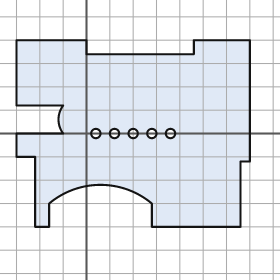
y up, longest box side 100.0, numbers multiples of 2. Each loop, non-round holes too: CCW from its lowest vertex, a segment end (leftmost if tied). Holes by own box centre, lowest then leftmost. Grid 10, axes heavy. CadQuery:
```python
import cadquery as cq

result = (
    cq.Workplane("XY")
    .moveTo(-22.0, -40.0)
    .lineTo(-16.0, -40.0)
    .lineTo(-16.0, -30.0)
    .threePointArc((6.0, -22.0), (28.0, -30.0))
    .lineTo(28.0, -40.0)
    .lineTo(66.0, -40.0)
    .lineTo(66.0, -12.0)
    .lineTo(70.0, -12.0)
    .lineTo(70.0, 40.0)
    .lineTo(46.0, 40.0)
    .lineTo(46.0, 34.0)
    .lineTo(0.0, 34.0)
    .lineTo(0.0, 40.0)
    .lineTo(-30.0, 40.0)
    .lineTo(-30.0, 12.0)
    .lineTo(-10.0, 12.0)
    .threePointArc((-12.0, 6.0), (-10.0, 0.0))
    .lineTo(-30.0, 0.0)
    .lineTo(-30.0, -10.0)
    .lineTo(-22.0, -10.0)
    .close()
    .moveTo(4.0, 0.0)
    .circle(2.0)
    .moveTo(12.0, 0.0)
    .circle(2.0)
    .moveTo(20.0, 0.0)
    .circle(2.0)
    .moveTo(28.0, 0.0)
    .circle(2.0)
    .moveTo(36.0, 0.0)
    .circle(2.0)
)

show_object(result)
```